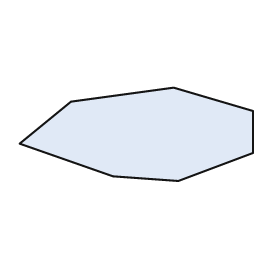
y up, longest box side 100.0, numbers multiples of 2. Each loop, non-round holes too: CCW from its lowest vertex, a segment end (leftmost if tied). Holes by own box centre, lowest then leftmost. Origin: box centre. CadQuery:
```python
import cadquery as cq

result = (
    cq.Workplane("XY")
    .moveTo(18.0, -20.0)
    .lineTo(50.0, -8.0)
    .lineTo(50.0, 10.0)
    .lineTo(16.0, 20.0)
    .lineTo(-28.0, 14.0)
    .lineTo(-50.0, -4.0)
    .lineTo(-10.0, -18.0)
    .close()
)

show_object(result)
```